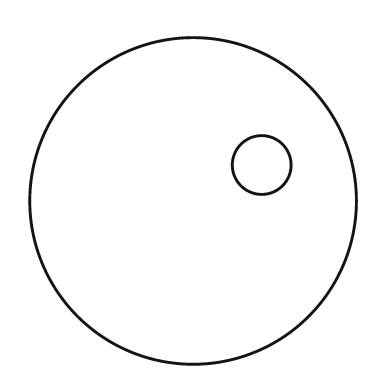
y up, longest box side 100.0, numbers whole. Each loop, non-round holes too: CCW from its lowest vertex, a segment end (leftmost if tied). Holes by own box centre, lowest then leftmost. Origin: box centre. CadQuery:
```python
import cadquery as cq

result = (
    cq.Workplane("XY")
    .moveTo(0.0, 0.0)
    .circle(50.0)
    .moveTo(21.0, 11.0)
    .circle(9.0)
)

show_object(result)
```